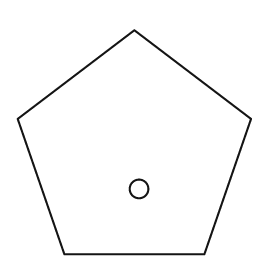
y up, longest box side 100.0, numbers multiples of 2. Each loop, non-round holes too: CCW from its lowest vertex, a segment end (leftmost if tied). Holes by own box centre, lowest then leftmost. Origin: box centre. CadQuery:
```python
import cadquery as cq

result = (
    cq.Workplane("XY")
    .moveTo(-30.0, -48.0)
    .lineTo(30.0, -48.0)
    .lineTo(50.0, 10.0)
    .lineTo(0.0, 48.0)
    .lineTo(-50.0, 10.0)
    .close()
    .moveTo(2.0, -20.0)
    .circle(4.0)
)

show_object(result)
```